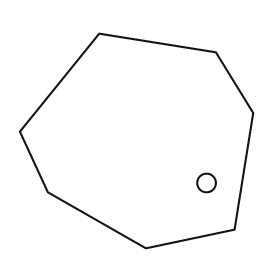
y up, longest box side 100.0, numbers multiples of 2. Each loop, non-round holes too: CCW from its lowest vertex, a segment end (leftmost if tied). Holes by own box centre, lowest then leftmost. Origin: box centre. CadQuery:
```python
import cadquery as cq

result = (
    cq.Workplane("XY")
    .moveTo(4.0, -46.0)
    .lineTo(42.0, -38.0)
    .lineTo(50.0, 12.0)
    .lineTo(34.0, 38.0)
    .lineTo(-16.0, 46.0)
    .lineTo(-50.0, 4.0)
    .lineTo(-38.0, -22.0)
    .close()
    .moveTo(30.0, -18.0)
    .circle(4.0)
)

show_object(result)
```